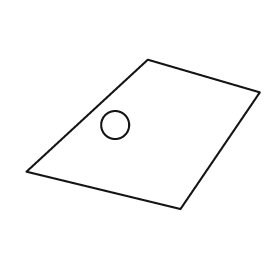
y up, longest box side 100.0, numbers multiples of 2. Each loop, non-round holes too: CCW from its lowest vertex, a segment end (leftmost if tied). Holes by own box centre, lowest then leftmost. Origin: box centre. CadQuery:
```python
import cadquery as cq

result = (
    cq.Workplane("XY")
    .moveTo(16.0, -32.0)
    .lineTo(50.0, 18.0)
    .lineTo(2.0, 32.0)
    .lineTo(-50.0, -16.0)
    .close()
    .moveTo(-12.0, 4.0)
    .circle(6.0)
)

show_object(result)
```